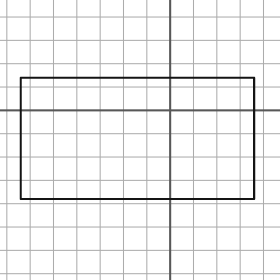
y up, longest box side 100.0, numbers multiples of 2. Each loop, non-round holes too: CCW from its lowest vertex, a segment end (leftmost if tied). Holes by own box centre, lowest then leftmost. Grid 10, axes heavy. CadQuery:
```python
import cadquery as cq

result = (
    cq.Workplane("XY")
    .moveTo(-64.0, -38.0)
    .lineTo(36.0, -38.0)
    .lineTo(36.0, 14.0)
    .lineTo(-64.0, 14.0)
    .close()
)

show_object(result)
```